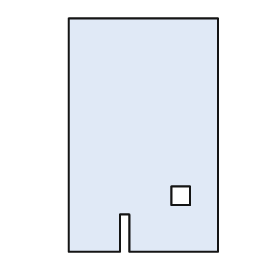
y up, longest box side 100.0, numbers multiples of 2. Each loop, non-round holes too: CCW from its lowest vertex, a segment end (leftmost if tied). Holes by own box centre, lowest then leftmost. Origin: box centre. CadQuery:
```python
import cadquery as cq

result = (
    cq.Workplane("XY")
    .moveTo(-32.0, -50.0)
    .lineTo(-10.0, -50.0)
    .lineTo(-10.0, -34.0)
    .lineTo(-6.0, -34.0)
    .lineTo(-6.0, -50.0)
    .lineTo(32.0, -50.0)
    .lineTo(32.0, 50.0)
    .lineTo(-32.0, 50.0)
    .close()
    .moveTo(12.0, -30.0)
    .lineTo(20.0, -30.0)
    .lineTo(20.0, -22.0)
    .lineTo(12.0, -22.0)
    .close()
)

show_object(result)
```